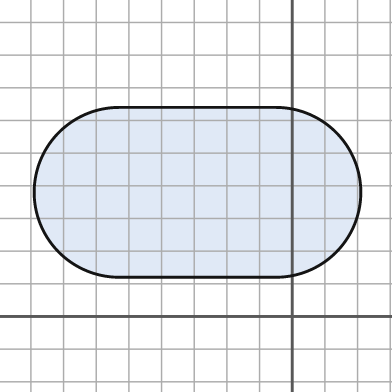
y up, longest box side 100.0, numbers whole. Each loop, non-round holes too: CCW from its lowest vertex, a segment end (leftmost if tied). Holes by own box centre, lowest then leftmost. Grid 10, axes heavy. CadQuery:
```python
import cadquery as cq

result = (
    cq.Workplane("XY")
    .moveTo(-53.0, 12.0)
    .lineTo(-5.0, 12.0)
    .threePointArc((21.0, 38.0), (-5.0, 64.0))
    .lineTo(-53.0, 64.0)
    .threePointArc((-79.0, 38.0), (-53.0, 12.0))
    .close()
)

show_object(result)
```